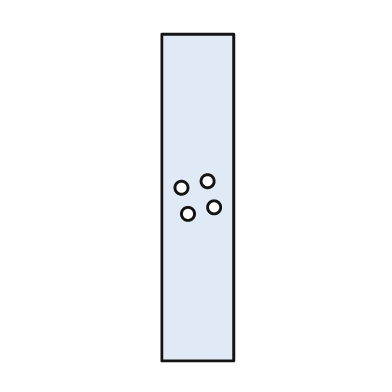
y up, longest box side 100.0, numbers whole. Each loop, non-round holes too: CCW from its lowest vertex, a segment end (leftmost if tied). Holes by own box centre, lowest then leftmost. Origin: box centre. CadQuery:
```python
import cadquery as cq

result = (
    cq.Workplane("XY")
    .moveTo(-11.0, -50.0)
    .lineTo(11.0, -50.0)
    .lineTo(11.0, 50.0)
    .lineTo(-11.0, 50.0)
    .close()
    .moveTo(-3.0, -5.0)
    .circle(2.0)
    .moveTo(5.0, -3.0)
    .circle(2.0)
    .moveTo(-5.0, 3.0)
    .circle(2.0)
    .moveTo(3.0, 5.0)
    .circle(2.0)
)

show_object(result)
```